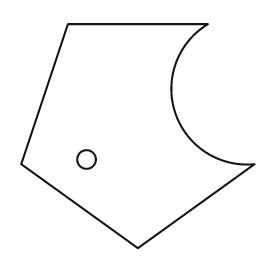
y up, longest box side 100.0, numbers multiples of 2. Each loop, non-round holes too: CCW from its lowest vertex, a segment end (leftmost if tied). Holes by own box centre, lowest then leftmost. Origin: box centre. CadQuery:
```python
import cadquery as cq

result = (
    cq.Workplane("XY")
    .moveTo(0.0, -48.0)
    .lineTo(50.0, -12.0)
    .threePointArc((16.0, 10.0), (30.0, 48.0))
    .lineTo(-30.0, 48.0)
    .lineTo(-50.0, -12.0)
    .close()
    .moveTo(-22.0, -10.0)
    .circle(4.0)
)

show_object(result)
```